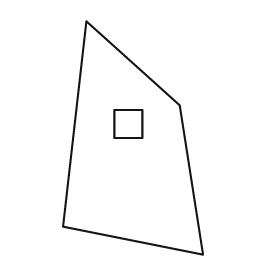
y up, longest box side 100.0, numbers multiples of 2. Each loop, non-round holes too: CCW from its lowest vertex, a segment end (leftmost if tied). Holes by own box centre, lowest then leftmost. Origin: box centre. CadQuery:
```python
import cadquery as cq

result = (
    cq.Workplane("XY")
    .moveTo(30.0, -50.0)
    .lineTo(20.0, 14.0)
    .lineTo(-20.0, 50.0)
    .lineTo(-30.0, -38.0)
    .close()
    .moveTo(-8.0, 0.0)
    .lineTo(4.0, 0.0)
    .lineTo(4.0, 12.0)
    .lineTo(-8.0, 12.0)
    .close()
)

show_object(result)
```